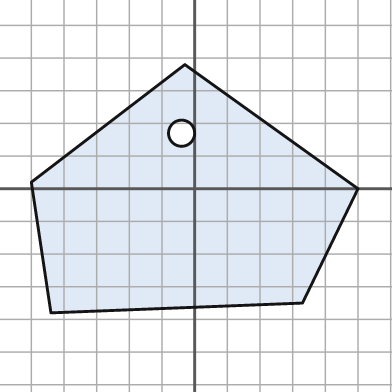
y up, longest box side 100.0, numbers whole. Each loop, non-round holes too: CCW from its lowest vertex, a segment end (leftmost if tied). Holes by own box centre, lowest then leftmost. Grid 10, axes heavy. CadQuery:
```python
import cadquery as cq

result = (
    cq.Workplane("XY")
    .moveTo(-44.0, -38.0)
    .lineTo(33.0, -35.0)
    .lineTo(50.0, 0.0)
    .lineTo(-3.0, 38.0)
    .lineTo(-50.0, 2.0)
    .close()
    .moveTo(-4.0, 17.0)
    .circle(4.0)
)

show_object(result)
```